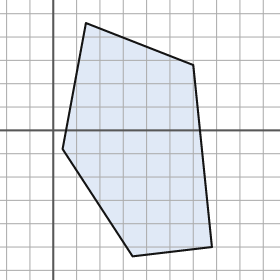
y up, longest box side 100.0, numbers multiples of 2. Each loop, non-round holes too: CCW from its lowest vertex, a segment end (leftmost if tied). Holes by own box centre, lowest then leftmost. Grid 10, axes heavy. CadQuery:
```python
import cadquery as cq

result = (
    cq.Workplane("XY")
    .moveTo(34.0, -54.0)
    .lineTo(68.0, -50.0)
    .lineTo(60.0, 28.0)
    .lineTo(14.0, 46.0)
    .lineTo(4.0, -8.0)
    .close()
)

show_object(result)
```